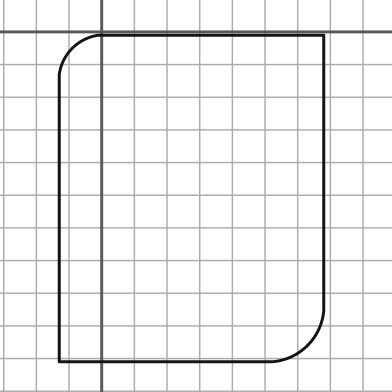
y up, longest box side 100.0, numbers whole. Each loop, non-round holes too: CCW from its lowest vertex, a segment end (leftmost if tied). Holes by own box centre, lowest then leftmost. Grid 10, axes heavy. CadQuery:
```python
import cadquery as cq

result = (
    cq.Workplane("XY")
    .moveTo(-13.0, -101.0)
    .lineTo(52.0, -101.0)
    .threePointArc((63.0, -96.0), (68.0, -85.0))
    .lineTo(68.0, -1.0)
    .lineTo(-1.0, -1.0)
    .threePointArc((-9.0, -5.0), (-13.0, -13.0))
    .close()
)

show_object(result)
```